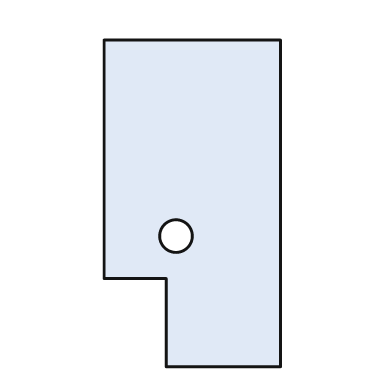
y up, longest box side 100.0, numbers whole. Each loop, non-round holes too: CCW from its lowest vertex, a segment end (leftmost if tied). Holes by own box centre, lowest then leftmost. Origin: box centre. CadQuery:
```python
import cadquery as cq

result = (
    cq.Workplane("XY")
    .moveTo(-8.0, -50.0)
    .lineTo(27.0, -50.0)
    .lineTo(27.0, 50.0)
    .lineTo(-27.0, 50.0)
    .lineTo(-27.0, -23.0)
    .lineTo(-8.0, -23.0)
    .close()
    .moveTo(-5.0, -10.0)
    .circle(5.0)
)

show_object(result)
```